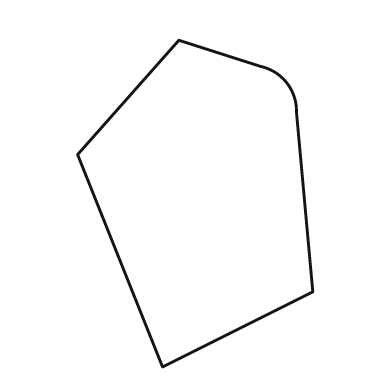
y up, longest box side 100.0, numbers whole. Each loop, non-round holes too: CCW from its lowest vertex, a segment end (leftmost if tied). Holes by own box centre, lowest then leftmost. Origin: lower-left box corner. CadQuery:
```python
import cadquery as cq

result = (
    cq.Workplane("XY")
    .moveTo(26.0, 0.0)
    .lineTo(72.0, 23.0)
    .lineTo(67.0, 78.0)
    .threePointArc((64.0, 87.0), (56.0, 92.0))
    .lineTo(31.0, 100.0)
    .lineTo(0.0, 65.0)
    .close()
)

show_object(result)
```